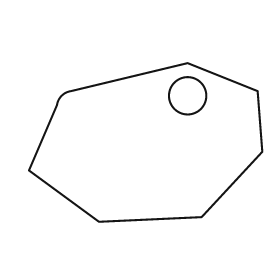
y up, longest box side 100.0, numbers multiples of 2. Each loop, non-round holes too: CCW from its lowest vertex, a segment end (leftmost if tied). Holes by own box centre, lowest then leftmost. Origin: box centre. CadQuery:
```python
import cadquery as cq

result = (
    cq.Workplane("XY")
    .moveTo(-20.0, -34.0)
    .lineTo(24.0, -32.0)
    .lineTo(50.0, -4.0)
    .lineTo(48.0, 22.0)
    .lineTo(18.0, 34.0)
    .lineTo(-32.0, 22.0)
    .threePointArc((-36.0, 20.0), (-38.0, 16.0))
    .lineTo(-50.0, -12.0)
    .close()
    .moveTo(18.0, 20.0)
    .circle(8.0)
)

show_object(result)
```